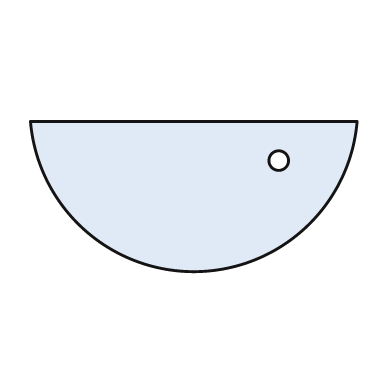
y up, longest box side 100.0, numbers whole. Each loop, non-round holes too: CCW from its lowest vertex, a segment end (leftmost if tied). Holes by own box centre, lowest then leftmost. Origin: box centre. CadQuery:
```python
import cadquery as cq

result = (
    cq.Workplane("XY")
    .moveTo(-50.0, 23.0)
    .threePointArc((0.0, -23.0), (50.0, 23.0))
    .close()
    .moveTo(26.0, 11.0)
    .circle(3.0)
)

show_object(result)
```